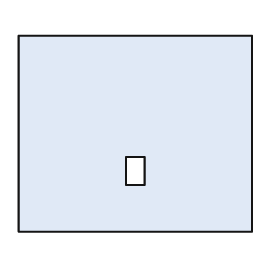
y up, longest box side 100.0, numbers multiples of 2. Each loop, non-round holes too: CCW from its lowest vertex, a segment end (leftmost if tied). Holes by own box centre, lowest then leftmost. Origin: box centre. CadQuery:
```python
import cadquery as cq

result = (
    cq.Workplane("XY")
    .moveTo(-50.0, -42.0)
    .lineTo(50.0, -42.0)
    .lineTo(50.0, 42.0)
    .lineTo(-50.0, 42.0)
    .close()
    .moveTo(-4.0, -22.0)
    .lineTo(4.0, -22.0)
    .lineTo(4.0, -10.0)
    .lineTo(-4.0, -10.0)
    .close()
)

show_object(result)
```